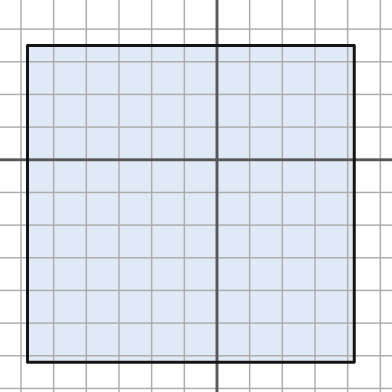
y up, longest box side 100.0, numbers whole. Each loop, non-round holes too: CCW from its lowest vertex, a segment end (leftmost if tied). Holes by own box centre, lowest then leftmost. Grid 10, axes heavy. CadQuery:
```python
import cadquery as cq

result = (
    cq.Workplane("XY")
    .moveTo(-58.0, -62.0)
    .lineTo(42.0, -62.0)
    .lineTo(42.0, 35.0)
    .lineTo(-58.0, 35.0)
    .close()
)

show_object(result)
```